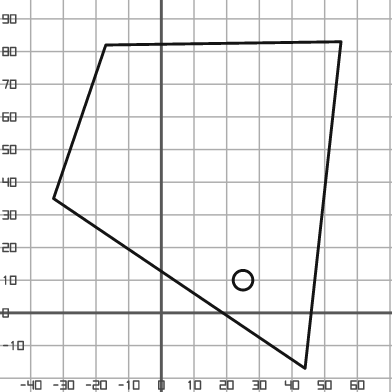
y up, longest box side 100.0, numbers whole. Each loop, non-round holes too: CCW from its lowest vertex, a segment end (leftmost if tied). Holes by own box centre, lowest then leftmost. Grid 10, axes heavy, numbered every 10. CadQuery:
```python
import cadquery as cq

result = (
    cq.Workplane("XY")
    .moveTo(44.0, -17.0)
    .lineTo(55.0, 83.0)
    .lineTo(-17.0, 82.0)
    .lineTo(-33.0, 35.0)
    .close()
    .moveTo(25.0, 10.0)
    .circle(3.0)
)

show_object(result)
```